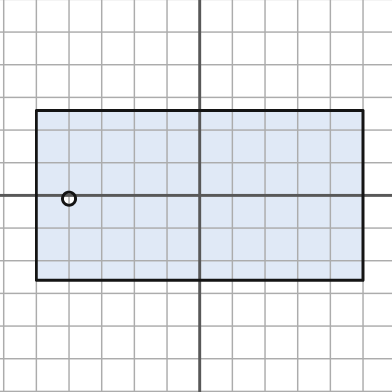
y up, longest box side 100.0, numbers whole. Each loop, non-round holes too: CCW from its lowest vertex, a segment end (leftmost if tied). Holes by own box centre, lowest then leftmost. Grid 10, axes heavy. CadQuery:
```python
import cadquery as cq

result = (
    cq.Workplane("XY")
    .moveTo(-50.0, -26.0)
    .lineTo(50.0, -26.0)
    .lineTo(50.0, 26.0)
    .lineTo(-50.0, 26.0)
    .close()
    .moveTo(-40.0, -1.0)
    .circle(2.0)
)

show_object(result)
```